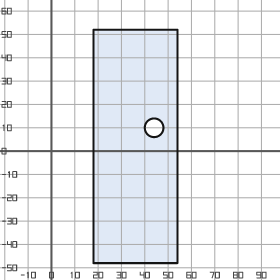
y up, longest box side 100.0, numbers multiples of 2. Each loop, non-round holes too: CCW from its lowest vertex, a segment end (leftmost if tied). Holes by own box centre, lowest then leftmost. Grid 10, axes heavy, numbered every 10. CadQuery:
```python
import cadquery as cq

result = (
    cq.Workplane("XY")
    .moveTo(18.0, -48.0)
    .lineTo(54.0, -48.0)
    .lineTo(54.0, 52.0)
    .lineTo(18.0, 52.0)
    .close()
    .moveTo(44.0, 10.0)
    .circle(4.0)
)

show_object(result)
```